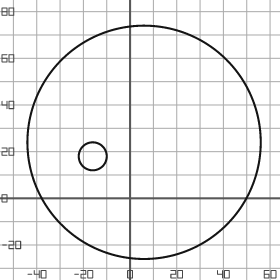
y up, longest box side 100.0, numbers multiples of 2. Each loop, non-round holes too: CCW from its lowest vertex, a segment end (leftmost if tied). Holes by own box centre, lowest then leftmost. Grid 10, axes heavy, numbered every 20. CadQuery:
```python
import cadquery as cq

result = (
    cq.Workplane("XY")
    .moveTo(6.0, 24.0)
    .circle(50.0)
    .moveTo(-16.0, 18.0)
    .circle(6.0)
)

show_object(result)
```